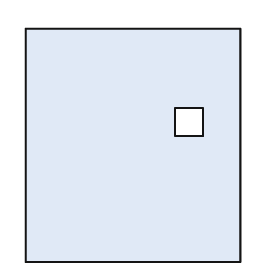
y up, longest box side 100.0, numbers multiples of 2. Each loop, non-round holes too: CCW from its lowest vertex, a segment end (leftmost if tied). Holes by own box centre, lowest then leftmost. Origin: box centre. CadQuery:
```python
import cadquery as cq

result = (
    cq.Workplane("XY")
    .moveTo(-46.0, -50.0)
    .lineTo(46.0, -50.0)
    .lineTo(46.0, 50.0)
    .lineTo(-46.0, 50.0)
    .close()
    .moveTo(18.0, 4.0)
    .lineTo(30.0, 4.0)
    .lineTo(30.0, 16.0)
    .lineTo(18.0, 16.0)
    .close()
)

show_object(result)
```